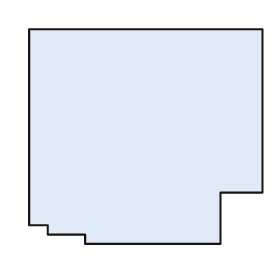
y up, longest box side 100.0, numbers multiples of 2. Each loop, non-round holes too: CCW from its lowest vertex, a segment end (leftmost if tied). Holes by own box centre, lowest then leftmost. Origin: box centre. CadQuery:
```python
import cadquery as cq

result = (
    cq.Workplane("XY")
    .moveTo(-26.0, -46.0)
    .lineTo(32.0, -46.0)
    .lineTo(32.0, -24.0)
    .lineTo(50.0, -24.0)
    .lineTo(50.0, 46.0)
    .lineTo(-50.0, 46.0)
    .lineTo(-50.0, -38.0)
    .lineTo(-42.0, -38.0)
    .lineTo(-42.0, -42.0)
    .lineTo(-26.0, -42.0)
    .close()
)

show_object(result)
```